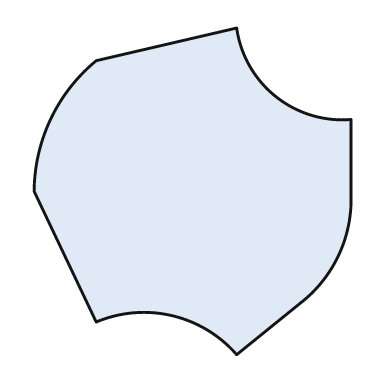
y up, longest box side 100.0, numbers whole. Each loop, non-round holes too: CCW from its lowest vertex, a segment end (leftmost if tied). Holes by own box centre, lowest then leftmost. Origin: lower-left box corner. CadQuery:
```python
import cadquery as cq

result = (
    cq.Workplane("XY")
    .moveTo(62.0, 0.0)
    .lineTo(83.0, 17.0)
    .threePointArc((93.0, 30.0), (97.0, 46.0))
    .lineTo(97.0, 72.0)
    .threePointArc((74.0, 79.0), (62.0, 100.0))
    .lineTo(19.0, 90.0)
    .threePointArc((5.0, 72.0), (0.0, 50.0))
    .lineTo(19.0, 10.0)
    .threePointArc((42.0, 12.0), (62.0, 0.0))
    .close()
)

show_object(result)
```